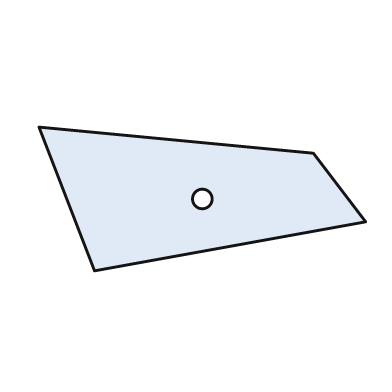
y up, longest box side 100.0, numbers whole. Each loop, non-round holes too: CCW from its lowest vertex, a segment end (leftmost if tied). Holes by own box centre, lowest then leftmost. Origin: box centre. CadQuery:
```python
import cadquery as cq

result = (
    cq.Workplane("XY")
    .moveTo(-33.0, -22.0)
    .lineTo(50.0, -7.0)
    .lineTo(34.0, 14.0)
    .lineTo(-50.0, 22.0)
    .close()
    .moveTo(0.0, 0.0)
    .circle(3.0)
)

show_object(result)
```